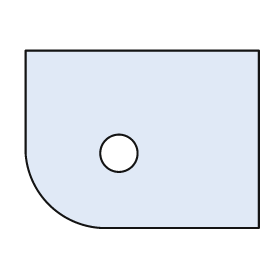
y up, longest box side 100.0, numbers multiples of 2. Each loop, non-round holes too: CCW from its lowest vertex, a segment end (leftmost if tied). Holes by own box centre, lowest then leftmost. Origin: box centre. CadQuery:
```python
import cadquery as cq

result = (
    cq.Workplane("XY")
    .moveTo(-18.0, -38.0)
    .lineTo(50.0, -38.0)
    .lineTo(50.0, 38.0)
    .lineTo(-50.0, 38.0)
    .lineTo(-50.0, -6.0)
    .threePointArc((-40.0, -28.0), (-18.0, -38.0))
    .close()
    .moveTo(-10.0, -6.0)
    .circle(8.0)
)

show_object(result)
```